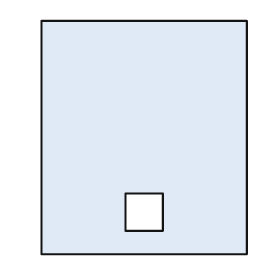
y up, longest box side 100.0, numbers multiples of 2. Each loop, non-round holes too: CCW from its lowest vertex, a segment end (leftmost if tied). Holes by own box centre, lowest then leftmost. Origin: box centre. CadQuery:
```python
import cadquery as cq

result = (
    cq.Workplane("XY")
    .moveTo(-44.0, -50.0)
    .lineTo(44.0, -50.0)
    .lineTo(44.0, 50.0)
    .lineTo(-44.0, 50.0)
    .close()
    .moveTo(-8.0, -40.0)
    .lineTo(8.0, -40.0)
    .lineTo(8.0, -24.0)
    .lineTo(-8.0, -24.0)
    .close()
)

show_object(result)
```